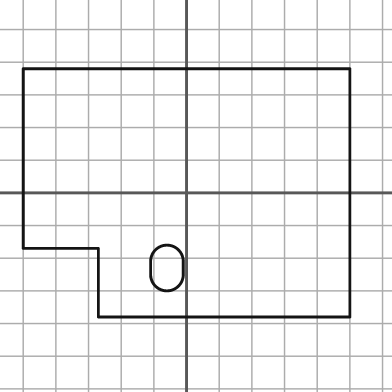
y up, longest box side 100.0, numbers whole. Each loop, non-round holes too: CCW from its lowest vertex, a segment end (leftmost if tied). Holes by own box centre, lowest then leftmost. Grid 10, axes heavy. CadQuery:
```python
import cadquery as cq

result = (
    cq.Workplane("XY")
    .moveTo(-27.0, -38.0)
    .lineTo(50.0, -38.0)
    .lineTo(50.0, 38.0)
    .lineTo(-50.0, 38.0)
    .lineTo(-50.0, -17.0)
    .lineTo(-27.0, -17.0)
    .close()
    .moveTo(-11.0, -25.0)
    .threePointArc((-6.0, -30.0), (-1.0, -25.0))
    .lineTo(-1.0, -21.0)
    .threePointArc((-6.0, -16.0), (-11.0, -21.0))
    .close()
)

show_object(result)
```